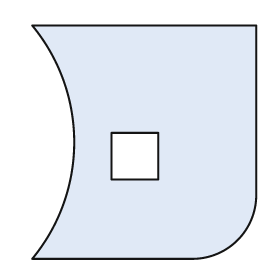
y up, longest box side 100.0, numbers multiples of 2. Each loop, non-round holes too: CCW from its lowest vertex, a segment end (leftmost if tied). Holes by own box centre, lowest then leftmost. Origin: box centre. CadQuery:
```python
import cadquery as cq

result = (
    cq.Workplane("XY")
    .moveTo(-48.0, -50.0)
    .lineTo(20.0, -50.0)
    .threePointArc((40.0, -42.0), (48.0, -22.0))
    .lineTo(48.0, 50.0)
    .lineTo(-48.0, 50.0)
    .threePointArc((-30.0, 0.0), (-48.0, -50.0))
    .close()
    .moveTo(-14.0, -16.0)
    .lineTo(6.0, -16.0)
    .lineTo(6.0, 4.0)
    .lineTo(-14.0, 4.0)
    .close()
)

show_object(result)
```